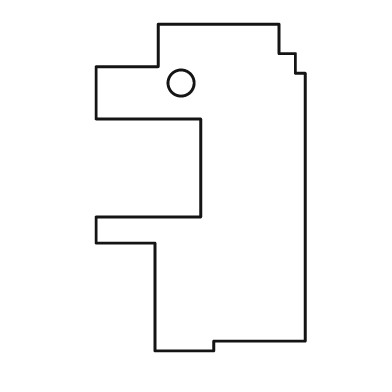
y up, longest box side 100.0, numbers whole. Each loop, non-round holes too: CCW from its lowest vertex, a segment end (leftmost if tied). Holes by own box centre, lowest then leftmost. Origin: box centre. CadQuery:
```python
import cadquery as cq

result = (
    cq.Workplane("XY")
    .moveTo(-14.0, -50.0)
    .lineTo(4.0, -50.0)
    .lineTo(4.0, -47.0)
    .lineTo(32.0, -47.0)
    .lineTo(32.0, 35.0)
    .lineTo(29.0, 35.0)
    .lineTo(29.0, 41.0)
    .lineTo(24.0, 41.0)
    .lineTo(24.0, 50.0)
    .lineTo(-13.0, 50.0)
    .lineTo(-13.0, 37.0)
    .lineTo(-32.0, 37.0)
    .lineTo(-32.0, 21.0)
    .lineTo(0.0, 21.0)
    .lineTo(0.0, -9.0)
    .lineTo(-32.0, -9.0)
    .lineTo(-32.0, -17.0)
    .lineTo(-14.0, -17.0)
    .close()
    .moveTo(-6.0, 32.0)
    .circle(4.0)
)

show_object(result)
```